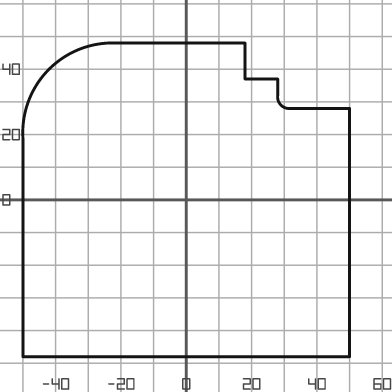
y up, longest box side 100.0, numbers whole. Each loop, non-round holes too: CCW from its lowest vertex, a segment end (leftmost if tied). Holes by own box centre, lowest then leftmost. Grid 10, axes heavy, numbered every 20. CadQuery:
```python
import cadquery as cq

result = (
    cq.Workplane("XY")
    .moveTo(-50.0, -48.0)
    .lineTo(50.0, -48.0)
    .lineTo(50.0, 28.0)
    .lineTo(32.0, 28.0)
    .threePointArc((29.0, 29.0), (28.0, 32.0))
    .lineTo(28.0, 37.0)
    .lineTo(18.0, 37.0)
    .lineTo(18.0, 48.0)
    .lineTo(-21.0, 48.0)
    .threePointArc((-42.0, 40.0), (-50.0, 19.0))
    .close()
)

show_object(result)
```